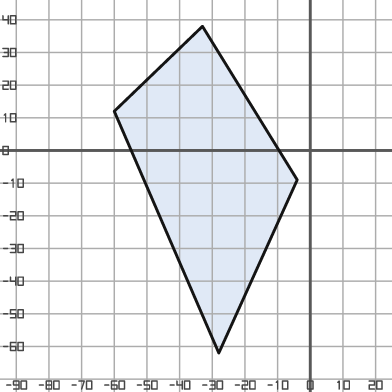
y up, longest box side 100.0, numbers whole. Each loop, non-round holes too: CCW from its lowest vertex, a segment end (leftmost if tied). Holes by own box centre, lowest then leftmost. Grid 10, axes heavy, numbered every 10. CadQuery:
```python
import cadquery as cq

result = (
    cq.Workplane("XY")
    .moveTo(-28.0, -62.0)
    .lineTo(-4.0, -9.0)
    .lineTo(-33.0, 38.0)
    .lineTo(-60.0, 12.0)
    .close()
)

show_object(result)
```